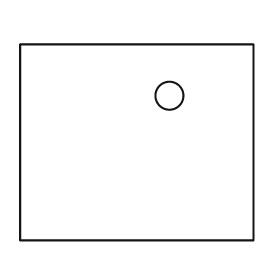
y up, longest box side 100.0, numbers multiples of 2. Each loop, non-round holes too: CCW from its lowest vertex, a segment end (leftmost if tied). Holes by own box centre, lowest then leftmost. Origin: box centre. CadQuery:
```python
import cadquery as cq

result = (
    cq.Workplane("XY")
    .moveTo(-50.0, -42.0)
    .lineTo(50.0, -42.0)
    .lineTo(50.0, 42.0)
    .lineTo(-50.0, 42.0)
    .close()
    .moveTo(14.0, 20.0)
    .circle(6.0)
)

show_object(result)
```